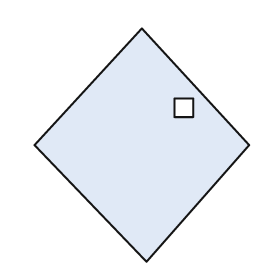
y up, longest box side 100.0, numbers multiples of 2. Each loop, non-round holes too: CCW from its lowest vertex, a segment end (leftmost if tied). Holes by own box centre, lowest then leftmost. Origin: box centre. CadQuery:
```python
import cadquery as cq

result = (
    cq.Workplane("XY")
    .moveTo(2.0, -50.0)
    .lineTo(46.0, 0.0)
    .lineTo(0.0, 50.0)
    .lineTo(-46.0, 0.0)
    .close()
    .moveTo(14.0, 12.0)
    .lineTo(22.0, 12.0)
    .lineTo(22.0, 20.0)
    .lineTo(14.0, 20.0)
    .close()
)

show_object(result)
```